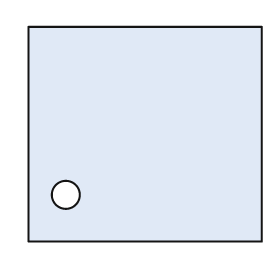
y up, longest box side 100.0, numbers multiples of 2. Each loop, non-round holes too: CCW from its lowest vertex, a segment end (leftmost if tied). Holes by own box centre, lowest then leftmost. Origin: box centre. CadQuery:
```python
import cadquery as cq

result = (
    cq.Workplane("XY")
    .moveTo(-50.0, -46.0)
    .lineTo(50.0, -46.0)
    .lineTo(50.0, 46.0)
    .lineTo(-50.0, 46.0)
    .close()
    .moveTo(-34.0, -26.0)
    .circle(6.0)
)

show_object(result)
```